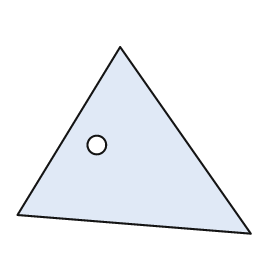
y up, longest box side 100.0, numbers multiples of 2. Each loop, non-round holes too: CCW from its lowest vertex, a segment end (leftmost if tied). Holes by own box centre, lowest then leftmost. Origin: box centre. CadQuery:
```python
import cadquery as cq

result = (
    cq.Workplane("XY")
    .moveTo(50.0, -40.0)
    .lineTo(-6.0, 40.0)
    .lineTo(-50.0, -32.0)
    .close()
    .moveTo(-16.0, -2.0)
    .circle(4.0)
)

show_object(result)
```